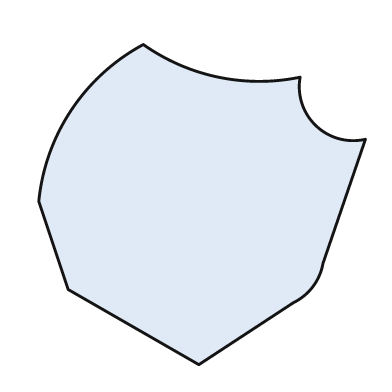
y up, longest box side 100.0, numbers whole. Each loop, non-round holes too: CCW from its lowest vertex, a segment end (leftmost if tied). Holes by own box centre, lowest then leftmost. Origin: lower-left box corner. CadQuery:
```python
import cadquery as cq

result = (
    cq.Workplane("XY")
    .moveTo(49.0, 0.0)
    .lineTo(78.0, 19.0)
    .threePointArc((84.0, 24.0), (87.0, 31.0))
    .lineTo(100.0, 69.0)
    .threePointArc((85.0, 73.0), (80.0, 88.0))
    .threePointArc((55.0, 88.0), (32.0, 98.0))
    .threePointArc((10.0, 78.0), (0.0, 50.0))
    .lineTo(9.0, 23.0)
    .close()
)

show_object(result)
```